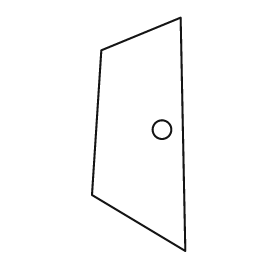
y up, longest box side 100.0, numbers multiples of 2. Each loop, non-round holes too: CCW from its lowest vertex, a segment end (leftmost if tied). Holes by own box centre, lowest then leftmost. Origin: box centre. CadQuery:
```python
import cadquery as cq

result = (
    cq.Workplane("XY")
    .moveTo(20.0, -50.0)
    .lineTo(18.0, 50.0)
    .lineTo(-16.0, 36.0)
    .lineTo(-20.0, -26.0)
    .close()
    .moveTo(10.0, 2.0)
    .circle(4.0)
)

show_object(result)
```